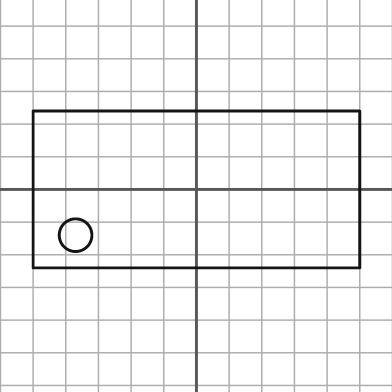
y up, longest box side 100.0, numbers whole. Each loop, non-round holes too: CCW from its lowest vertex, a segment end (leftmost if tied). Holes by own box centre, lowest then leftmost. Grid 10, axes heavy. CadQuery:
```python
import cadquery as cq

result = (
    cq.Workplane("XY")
    .moveTo(-50.0, -24.0)
    .lineTo(50.0, -24.0)
    .lineTo(50.0, 24.0)
    .lineTo(-50.0, 24.0)
    .close()
    .moveTo(-37.0, -14.0)
    .circle(5.0)
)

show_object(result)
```